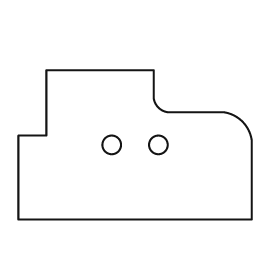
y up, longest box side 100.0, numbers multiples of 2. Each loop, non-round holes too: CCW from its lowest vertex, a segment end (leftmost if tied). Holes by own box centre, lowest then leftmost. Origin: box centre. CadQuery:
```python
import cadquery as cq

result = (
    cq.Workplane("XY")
    .moveTo(-50.0, -32.0)
    .lineTo(50.0, -32.0)
    .lineTo(50.0, 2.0)
    .threePointArc((46.0, 10.0), (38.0, 14.0))
    .lineTo(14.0, 14.0)
    .threePointArc((10.0, 16.0), (8.0, 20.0))
    .lineTo(8.0, 32.0)
    .lineTo(-38.0, 32.0)
    .lineTo(-38.0, 4.0)
    .lineTo(-50.0, 4.0)
    .close()
    .moveTo(-10.0, 0.0)
    .circle(4.0)
    .moveTo(10.0, 0.0)
    .circle(4.0)
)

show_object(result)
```